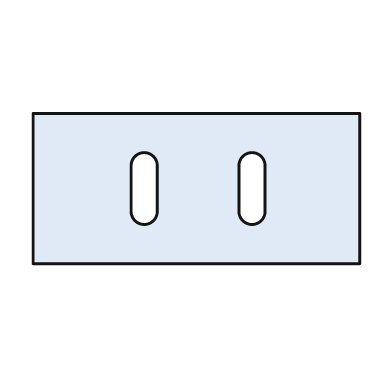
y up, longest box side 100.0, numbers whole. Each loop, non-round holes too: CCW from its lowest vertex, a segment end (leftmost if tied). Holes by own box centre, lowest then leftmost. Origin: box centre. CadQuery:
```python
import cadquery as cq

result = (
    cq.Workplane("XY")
    .moveTo(-50.0, -23.0)
    .lineTo(50.0, -23.0)
    .lineTo(50.0, 23.0)
    .lineTo(-50.0, 23.0)
    .close()
    .moveTo(-20.0, -7.0)
    .threePointArc((-16.0, -11.0), (-12.0, -7.0))
    .lineTo(-12.0, 7.0)
    .threePointArc((-16.0, 11.0), (-20.0, 7.0))
    .close()
    .moveTo(13.0, -7.0)
    .threePointArc((17.0, -11.0), (21.0, -7.0))
    .lineTo(21.0, 7.0)
    .threePointArc((17.0, 11.0), (13.0, 7.0))
    .close()
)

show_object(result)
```